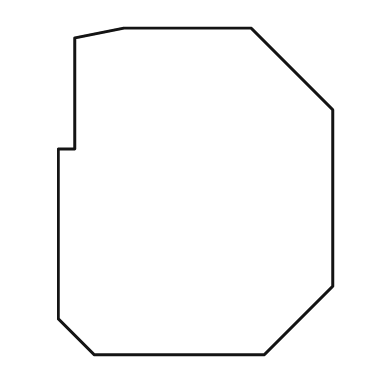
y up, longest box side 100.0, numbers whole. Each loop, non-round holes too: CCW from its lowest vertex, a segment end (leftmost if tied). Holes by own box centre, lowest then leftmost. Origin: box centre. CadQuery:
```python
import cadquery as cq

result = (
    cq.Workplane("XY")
    .moveTo(-31.0, -50.0)
    .lineTo(21.0, -50.0)
    .lineTo(42.0, -29.0)
    .lineTo(42.0, 25.0)
    .lineTo(17.0, 50.0)
    .lineTo(-22.0, 50.0)
    .lineTo(-37.0, 47.0)
    .lineTo(-37.0, 13.0)
    .lineTo(-42.0, 13.0)
    .lineTo(-42.0, -39.0)
    .close()
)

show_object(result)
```